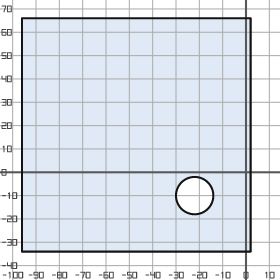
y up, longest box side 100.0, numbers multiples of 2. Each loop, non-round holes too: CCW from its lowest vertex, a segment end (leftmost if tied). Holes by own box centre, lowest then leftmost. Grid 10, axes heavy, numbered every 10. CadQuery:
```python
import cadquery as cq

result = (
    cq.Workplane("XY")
    .moveTo(-96.0, -34.0)
    .lineTo(2.0, -34.0)
    .lineTo(2.0, 66.0)
    .lineTo(-96.0, 66.0)
    .close()
    .moveTo(-22.0, -10.0)
    .circle(8.0)
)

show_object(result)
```